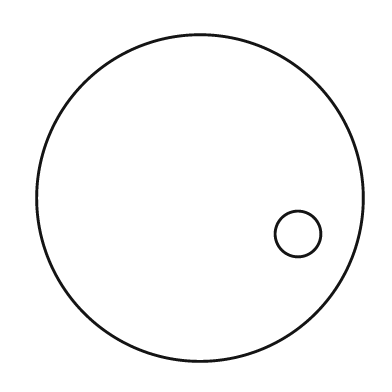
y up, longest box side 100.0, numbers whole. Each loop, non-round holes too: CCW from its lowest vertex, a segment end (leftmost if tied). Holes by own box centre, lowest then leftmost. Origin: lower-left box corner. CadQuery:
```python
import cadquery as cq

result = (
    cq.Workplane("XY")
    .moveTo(50.0, 50.0)
    .circle(50.0)
    .moveTo(80.0, 39.0)
    .circle(7.0)
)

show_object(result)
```